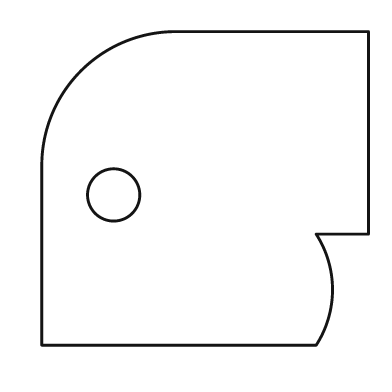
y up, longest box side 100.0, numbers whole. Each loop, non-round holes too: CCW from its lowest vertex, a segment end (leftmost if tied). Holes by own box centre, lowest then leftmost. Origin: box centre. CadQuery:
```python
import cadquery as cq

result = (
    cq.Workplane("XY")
    .moveTo(-50.0, -48.0)
    .lineTo(34.0, -48.0)
    .threePointArc((39.0, -31.0), (34.0, -14.0))
    .lineTo(50.0, -14.0)
    .lineTo(50.0, 48.0)
    .lineTo(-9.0, 48.0)
    .threePointArc((-38.0, 36.0), (-50.0, 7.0))
    .close()
    .moveTo(-28.0, -2.0)
    .circle(8.0)
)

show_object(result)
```